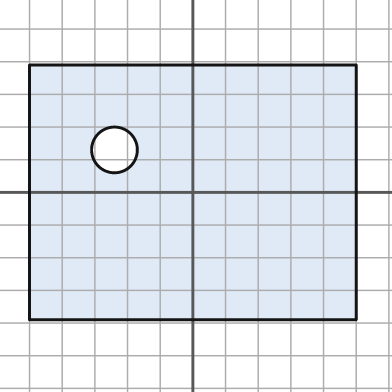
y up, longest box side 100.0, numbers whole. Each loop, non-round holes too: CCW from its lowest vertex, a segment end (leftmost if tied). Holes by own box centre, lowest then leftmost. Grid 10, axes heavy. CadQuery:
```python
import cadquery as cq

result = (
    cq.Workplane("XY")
    .moveTo(-50.0, -39.0)
    .lineTo(50.0, -39.0)
    .lineTo(50.0, 39.0)
    .lineTo(-50.0, 39.0)
    .close()
    .moveTo(-24.0, 13.0)
    .circle(7.0)
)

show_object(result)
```